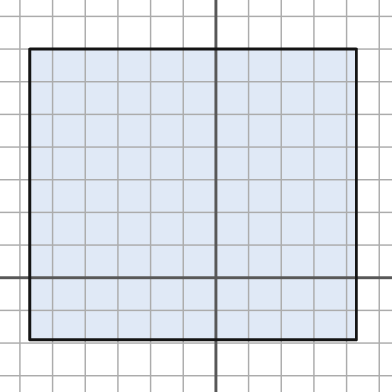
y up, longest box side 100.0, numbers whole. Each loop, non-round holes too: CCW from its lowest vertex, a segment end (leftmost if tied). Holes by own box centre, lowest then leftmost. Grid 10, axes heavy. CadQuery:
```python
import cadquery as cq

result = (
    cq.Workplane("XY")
    .moveTo(-57.0, -19.0)
    .lineTo(43.0, -19.0)
    .lineTo(43.0, 70.0)
    .lineTo(-57.0, 70.0)
    .close()
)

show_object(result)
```